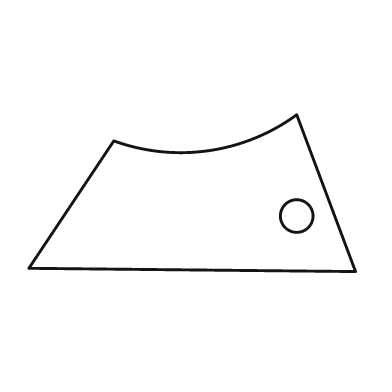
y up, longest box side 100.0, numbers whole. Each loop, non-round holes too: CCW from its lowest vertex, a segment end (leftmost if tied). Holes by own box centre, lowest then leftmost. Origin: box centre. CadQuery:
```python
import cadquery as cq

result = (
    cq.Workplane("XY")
    .moveTo(50.0, -24.0)
    .lineTo(32.0, 24.0)
    .threePointArc((5.0, 13.0), (-24.0, 16.0))
    .lineTo(-50.0, -23.0)
    .close()
    .moveTo(32.0, -7.0)
    .circle(5.0)
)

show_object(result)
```